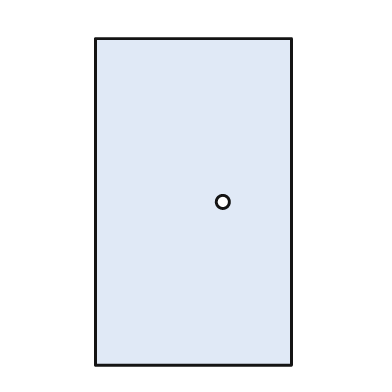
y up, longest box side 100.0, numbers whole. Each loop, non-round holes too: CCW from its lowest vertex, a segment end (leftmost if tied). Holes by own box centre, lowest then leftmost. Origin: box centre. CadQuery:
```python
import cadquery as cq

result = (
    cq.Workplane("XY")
    .moveTo(-30.0, -50.0)
    .lineTo(30.0, -50.0)
    .lineTo(30.0, 50.0)
    .lineTo(-30.0, 50.0)
    .close()
    .moveTo(9.0, 0.0)
    .circle(2.0)
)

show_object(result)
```